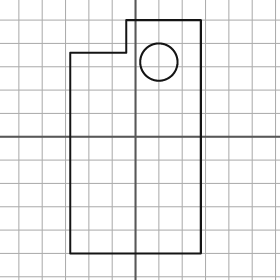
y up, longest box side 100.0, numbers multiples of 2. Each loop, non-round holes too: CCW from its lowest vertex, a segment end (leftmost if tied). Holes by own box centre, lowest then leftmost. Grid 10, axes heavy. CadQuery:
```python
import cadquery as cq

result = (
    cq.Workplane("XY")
    .moveTo(-28.0, -50.0)
    .lineTo(28.0, -50.0)
    .lineTo(28.0, 50.0)
    .lineTo(-4.0, 50.0)
    .lineTo(-4.0, 36.0)
    .lineTo(-28.0, 36.0)
    .close()
    .moveTo(10.0, 32.0)
    .circle(8.0)
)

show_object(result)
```